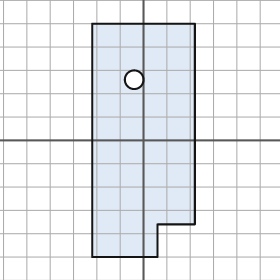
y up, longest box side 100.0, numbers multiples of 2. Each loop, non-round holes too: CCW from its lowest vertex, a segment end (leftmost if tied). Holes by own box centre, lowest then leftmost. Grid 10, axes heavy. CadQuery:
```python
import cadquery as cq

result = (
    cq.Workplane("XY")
    .moveTo(-22.0, -50.0)
    .lineTo(6.0, -50.0)
    .lineTo(6.0, -36.0)
    .lineTo(22.0, -36.0)
    .lineTo(22.0, 50.0)
    .lineTo(-22.0, 50.0)
    .close()
    .moveTo(-4.0, 26.0)
    .circle(4.0)
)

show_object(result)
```